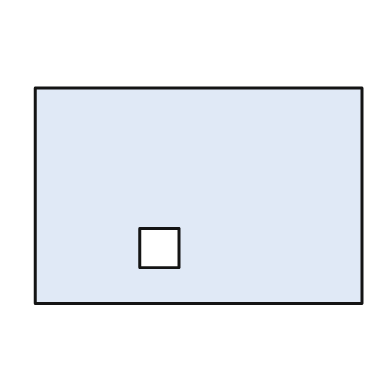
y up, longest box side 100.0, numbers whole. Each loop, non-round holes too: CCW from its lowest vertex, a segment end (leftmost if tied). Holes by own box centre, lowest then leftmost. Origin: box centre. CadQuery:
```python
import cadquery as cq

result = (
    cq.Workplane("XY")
    .moveTo(-50.0, -33.0)
    .lineTo(50.0, -33.0)
    .lineTo(50.0, 33.0)
    .lineTo(-50.0, 33.0)
    .close()
    .moveTo(-18.0, -22.0)
    .lineTo(-6.0, -22.0)
    .lineTo(-6.0, -10.0)
    .lineTo(-18.0, -10.0)
    .close()
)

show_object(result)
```